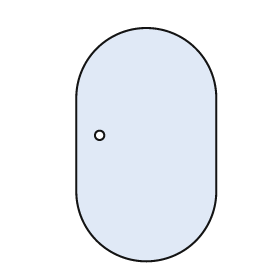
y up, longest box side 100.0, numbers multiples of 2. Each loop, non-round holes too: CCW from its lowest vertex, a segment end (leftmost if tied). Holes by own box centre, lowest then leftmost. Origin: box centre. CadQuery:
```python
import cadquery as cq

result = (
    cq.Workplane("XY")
    .moveTo(-30.0, -20.0)
    .threePointArc((0.0, -50.0), (30.0, -20.0))
    .lineTo(30.0, 20.0)
    .threePointArc((0.0, 50.0), (-30.0, 20.0))
    .close()
    .moveTo(-20.0, 4.0)
    .circle(2.0)
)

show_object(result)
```